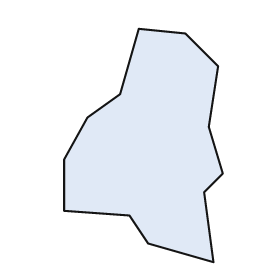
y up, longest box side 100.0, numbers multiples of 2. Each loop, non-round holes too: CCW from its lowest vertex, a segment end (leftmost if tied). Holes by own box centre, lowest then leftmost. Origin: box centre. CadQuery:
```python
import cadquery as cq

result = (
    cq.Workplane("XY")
    .moveTo(30.0, -50.0)
    .lineTo(26.0, -20.0)
    .lineTo(34.0, -12.0)
    .lineTo(28.0, 8.0)
    .lineTo(32.0, 34.0)
    .lineTo(18.0, 48.0)
    .lineTo(-2.0, 50.0)
    .lineTo(-10.0, 22.0)
    .lineTo(-24.0, 12.0)
    .lineTo(-34.0, -6.0)
    .lineTo(-34.0, -28.0)
    .lineTo(-6.0, -30.0)
    .lineTo(2.0, -42.0)
    .close()
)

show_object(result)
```